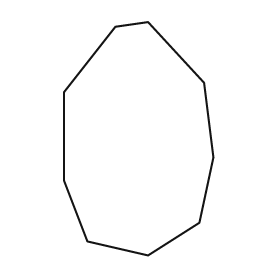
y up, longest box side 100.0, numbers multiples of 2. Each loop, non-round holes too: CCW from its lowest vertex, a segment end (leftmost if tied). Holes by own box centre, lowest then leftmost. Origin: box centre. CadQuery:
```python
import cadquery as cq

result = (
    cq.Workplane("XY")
    .moveTo(4.0, -50.0)
    .lineTo(26.0, -36.0)
    .lineTo(32.0, -8.0)
    .lineTo(28.0, 24.0)
    .lineTo(4.0, 50.0)
    .lineTo(-10.0, 48.0)
    .lineTo(-32.0, 20.0)
    .lineTo(-32.0, -18.0)
    .lineTo(-22.0, -44.0)
    .close()
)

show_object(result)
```